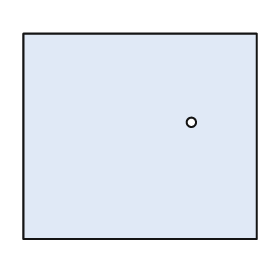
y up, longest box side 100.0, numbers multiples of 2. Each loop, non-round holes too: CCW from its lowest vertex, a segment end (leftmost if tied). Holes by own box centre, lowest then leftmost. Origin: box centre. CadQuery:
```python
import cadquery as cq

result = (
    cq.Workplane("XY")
    .moveTo(-50.0, -44.0)
    .lineTo(50.0, -44.0)
    .lineTo(50.0, 44.0)
    .lineTo(-50.0, 44.0)
    .close()
    .moveTo(22.0, 6.0)
    .circle(2.0)
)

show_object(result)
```